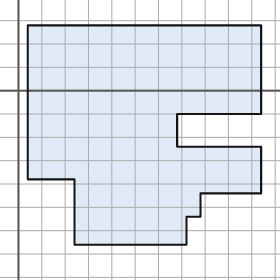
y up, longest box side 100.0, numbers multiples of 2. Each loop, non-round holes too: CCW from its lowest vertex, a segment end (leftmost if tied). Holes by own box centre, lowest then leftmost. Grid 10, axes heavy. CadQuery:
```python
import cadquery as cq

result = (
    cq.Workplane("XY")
    .moveTo(24.0, -66.0)
    .lineTo(72.0, -66.0)
    .lineTo(72.0, -54.0)
    .lineTo(78.0, -54.0)
    .lineTo(78.0, -44.0)
    .lineTo(104.0, -44.0)
    .lineTo(104.0, -24.0)
    .lineTo(68.0, -24.0)
    .lineTo(68.0, -10.0)
    .lineTo(104.0, -10.0)
    .lineTo(104.0, 28.0)
    .lineTo(4.0, 28.0)
    .lineTo(4.0, -38.0)
    .lineTo(24.0, -38.0)
    .close()
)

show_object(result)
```